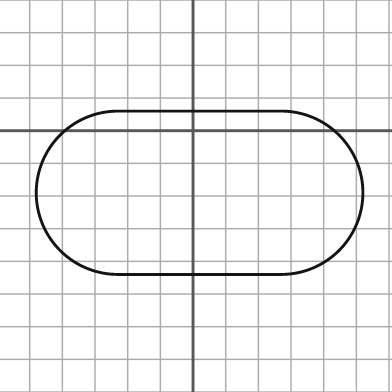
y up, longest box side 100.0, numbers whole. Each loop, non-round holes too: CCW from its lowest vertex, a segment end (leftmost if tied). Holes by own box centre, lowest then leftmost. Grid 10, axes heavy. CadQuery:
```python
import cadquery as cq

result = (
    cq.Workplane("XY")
    .moveTo(-23.0, -44.0)
    .lineTo(27.0, -44.0)
    .threePointArc((52.0, -19.0), (27.0, 6.0))
    .lineTo(-23.0, 6.0)
    .threePointArc((-48.0, -19.0), (-23.0, -44.0))
    .close()
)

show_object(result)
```